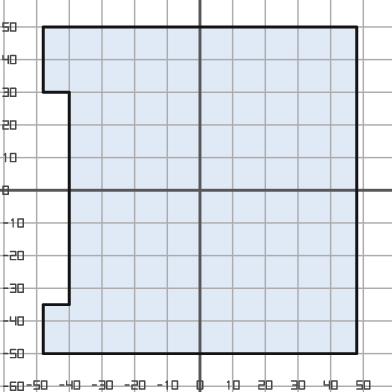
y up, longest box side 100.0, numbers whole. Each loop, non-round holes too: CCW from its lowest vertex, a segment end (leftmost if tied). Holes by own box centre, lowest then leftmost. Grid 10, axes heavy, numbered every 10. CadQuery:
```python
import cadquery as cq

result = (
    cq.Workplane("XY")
    .moveTo(-48.0, -50.0)
    .lineTo(48.0, -50.0)
    .lineTo(48.0, 50.0)
    .lineTo(-48.0, 50.0)
    .lineTo(-48.0, 30.0)
    .lineTo(-40.0, 30.0)
    .lineTo(-40.0, -35.0)
    .lineTo(-48.0, -35.0)
    .close()
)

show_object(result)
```